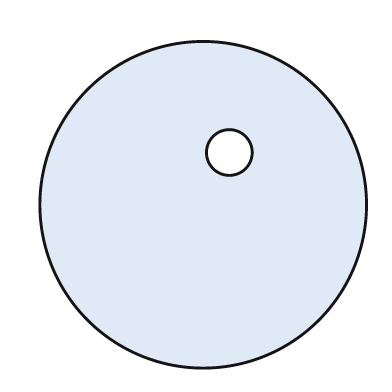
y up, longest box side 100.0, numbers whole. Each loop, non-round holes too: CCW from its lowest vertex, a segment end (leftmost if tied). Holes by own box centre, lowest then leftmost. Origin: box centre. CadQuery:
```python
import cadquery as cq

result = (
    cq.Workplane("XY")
    .moveTo(0.0, 0.0)
    .circle(50.0)
    .moveTo(8.0, 16.0)
    .circle(7.0)
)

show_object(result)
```